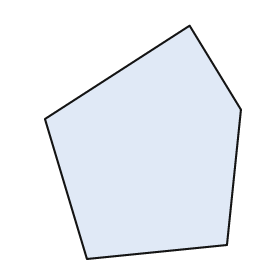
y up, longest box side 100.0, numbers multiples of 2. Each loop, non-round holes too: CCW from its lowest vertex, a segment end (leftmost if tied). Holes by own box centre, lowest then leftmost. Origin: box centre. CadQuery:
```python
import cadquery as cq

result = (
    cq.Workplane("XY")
    .moveTo(-24.0, -50.0)
    .lineTo(36.0, -44.0)
    .lineTo(42.0, 14.0)
    .lineTo(20.0, 50.0)
    .lineTo(-42.0, 10.0)
    .close()
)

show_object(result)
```